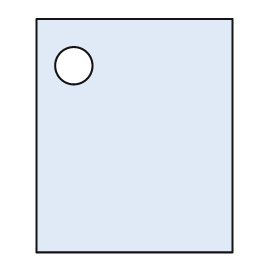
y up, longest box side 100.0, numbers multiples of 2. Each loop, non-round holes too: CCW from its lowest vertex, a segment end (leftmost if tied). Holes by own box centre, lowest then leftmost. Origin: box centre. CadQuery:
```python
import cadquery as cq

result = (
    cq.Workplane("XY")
    .moveTo(-42.0, -50.0)
    .lineTo(42.0, -50.0)
    .lineTo(42.0, 50.0)
    .lineTo(-42.0, 50.0)
    .close()
    .moveTo(-26.0, 30.0)
    .circle(8.0)
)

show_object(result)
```